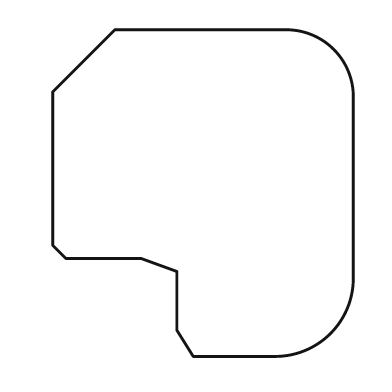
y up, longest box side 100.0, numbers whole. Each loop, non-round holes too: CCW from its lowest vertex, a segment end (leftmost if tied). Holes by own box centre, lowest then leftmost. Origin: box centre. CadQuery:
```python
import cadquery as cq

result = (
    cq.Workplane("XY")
    .moveTo(-3.0, -50.0)
    .lineTo(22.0, -50.0)
    .threePointArc((39.0, -43.0), (46.0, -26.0))
    .lineTo(46.0, 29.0)
    .threePointArc((40.0, 44.0), (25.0, 50.0))
    .lineTo(-27.0, 50.0)
    .lineTo(-46.0, 31.0)
    .lineTo(-46.0, -16.0)
    .lineTo(-42.0, -20.0)
    .lineTo(-19.0, -20.0)
    .lineTo(-8.0, -24.0)
    .lineTo(-8.0, -42.0)
    .close()
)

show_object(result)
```